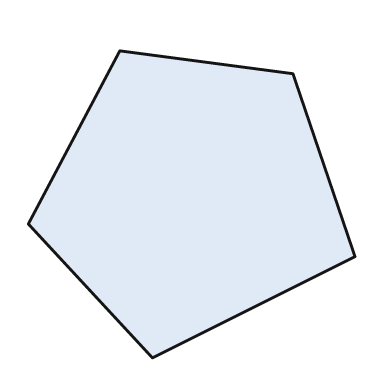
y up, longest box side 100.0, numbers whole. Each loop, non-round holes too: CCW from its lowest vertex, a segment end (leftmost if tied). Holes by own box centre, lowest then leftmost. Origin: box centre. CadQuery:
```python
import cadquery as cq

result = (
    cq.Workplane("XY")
    .moveTo(-12.0, -47.0)
    .lineTo(50.0, -16.0)
    .lineTo(31.0, 40.0)
    .lineTo(-22.0, 47.0)
    .lineTo(-50.0, -6.0)
    .close()
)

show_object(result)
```